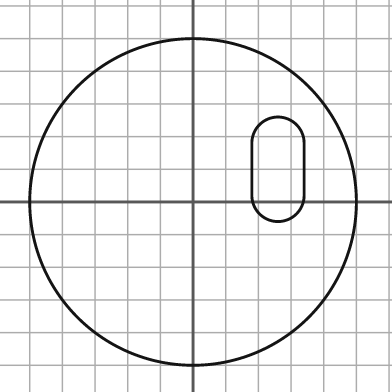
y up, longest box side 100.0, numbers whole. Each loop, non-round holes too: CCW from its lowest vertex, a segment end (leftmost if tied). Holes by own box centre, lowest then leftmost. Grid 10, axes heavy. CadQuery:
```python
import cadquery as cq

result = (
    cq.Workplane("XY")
    .moveTo(0.0, 0.0)
    .circle(50.0)
    .moveTo(18.0, 2.0)
    .threePointArc((26.0, -6.0), (34.0, 2.0))
    .lineTo(34.0, 18.0)
    .threePointArc((26.0, 26.0), (18.0, 18.0))
    .close()
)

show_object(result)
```